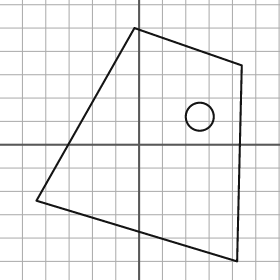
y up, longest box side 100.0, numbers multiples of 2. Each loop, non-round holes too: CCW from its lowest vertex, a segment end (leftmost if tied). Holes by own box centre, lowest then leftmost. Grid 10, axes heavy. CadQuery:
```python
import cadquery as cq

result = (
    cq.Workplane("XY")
    .moveTo(42.0, -50.0)
    .lineTo(44.0, 34.0)
    .lineTo(-2.0, 50.0)
    .lineTo(-44.0, -24.0)
    .close()
    .moveTo(26.0, 12.0)
    .circle(6.0)
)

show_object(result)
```